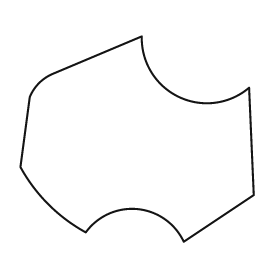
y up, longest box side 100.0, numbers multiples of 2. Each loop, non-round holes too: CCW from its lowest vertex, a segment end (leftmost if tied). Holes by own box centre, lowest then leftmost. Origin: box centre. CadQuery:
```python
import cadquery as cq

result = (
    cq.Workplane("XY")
    .moveTo(20.0, -44.0)
    .lineTo(50.0, -24.0)
    .lineTo(48.0, 22.0)
    .threePointArc((18.0, 18.0), (2.0, 44.0))
    .lineTo(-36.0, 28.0)
    .threePointArc((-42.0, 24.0), (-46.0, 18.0))
    .lineTo(-50.0, -12.0)
    .threePointArc((-38.0, -28.0), (-22.0, -40.0))
    .threePointArc((0.0, -30.0), (20.0, -44.0))
    .close()
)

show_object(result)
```